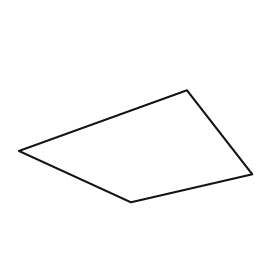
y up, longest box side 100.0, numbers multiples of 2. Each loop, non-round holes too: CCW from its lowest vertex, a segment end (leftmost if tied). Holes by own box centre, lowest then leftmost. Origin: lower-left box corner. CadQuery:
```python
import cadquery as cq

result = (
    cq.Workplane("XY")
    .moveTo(48.0, 0.0)
    .lineTo(100.0, 12.0)
    .lineTo(72.0, 48.0)
    .lineTo(0.0, 22.0)
    .close()
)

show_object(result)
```